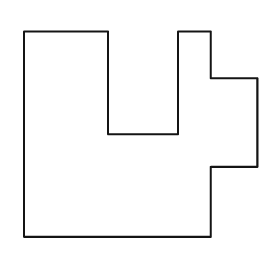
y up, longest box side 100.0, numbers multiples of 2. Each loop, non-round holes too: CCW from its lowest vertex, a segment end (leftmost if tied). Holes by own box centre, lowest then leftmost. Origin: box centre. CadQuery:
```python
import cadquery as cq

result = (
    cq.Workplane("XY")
    .moveTo(-50.0, -44.0)
    .lineTo(30.0, -44.0)
    .lineTo(30.0, -14.0)
    .lineTo(50.0, -14.0)
    .lineTo(50.0, 24.0)
    .lineTo(30.0, 24.0)
    .lineTo(30.0, 44.0)
    .lineTo(16.0, 44.0)
    .lineTo(16.0, 0.0)
    .lineTo(-14.0, 0.0)
    .lineTo(-14.0, 44.0)
    .lineTo(-50.0, 44.0)
    .close()
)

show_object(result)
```